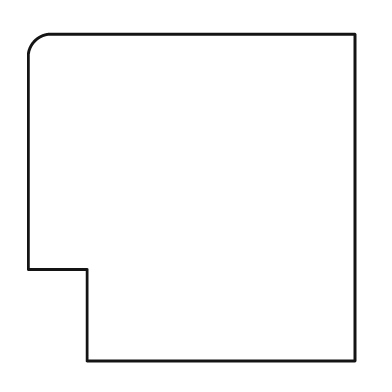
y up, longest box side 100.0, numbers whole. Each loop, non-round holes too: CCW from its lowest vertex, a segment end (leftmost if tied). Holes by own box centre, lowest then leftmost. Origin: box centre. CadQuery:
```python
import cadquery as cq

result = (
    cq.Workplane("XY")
    .moveTo(-32.0, -50.0)
    .lineTo(50.0, -50.0)
    .lineTo(50.0, 50.0)
    .lineTo(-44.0, 50.0)
    .threePointArc((-48.0, 48.0), (-50.0, 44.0))
    .lineTo(-50.0, -22.0)
    .lineTo(-32.0, -22.0)
    .close()
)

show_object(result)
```